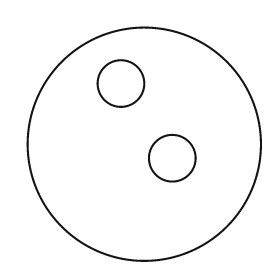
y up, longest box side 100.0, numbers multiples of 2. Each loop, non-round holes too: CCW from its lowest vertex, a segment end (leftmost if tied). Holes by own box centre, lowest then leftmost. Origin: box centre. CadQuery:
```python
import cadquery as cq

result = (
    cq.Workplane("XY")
    .moveTo(0.0, 0.0)
    .circle(50.0)
    .moveTo(12.0, -6.0)
    .circle(10.0)
    .moveTo(-10.0, 26.0)
    .circle(10.0)
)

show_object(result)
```